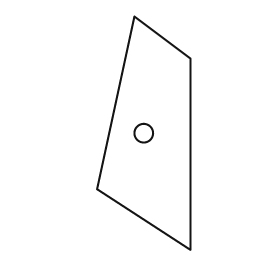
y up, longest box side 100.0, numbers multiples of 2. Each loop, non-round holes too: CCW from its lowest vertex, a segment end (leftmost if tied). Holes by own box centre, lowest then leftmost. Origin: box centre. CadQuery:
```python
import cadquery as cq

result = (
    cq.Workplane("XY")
    .moveTo(20.0, -50.0)
    .lineTo(20.0, 32.0)
    .lineTo(-4.0, 50.0)
    .lineTo(-20.0, -24.0)
    .close()
    .moveTo(0.0, 0.0)
    .circle(4.0)
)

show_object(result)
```